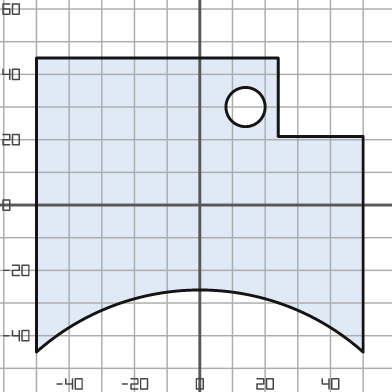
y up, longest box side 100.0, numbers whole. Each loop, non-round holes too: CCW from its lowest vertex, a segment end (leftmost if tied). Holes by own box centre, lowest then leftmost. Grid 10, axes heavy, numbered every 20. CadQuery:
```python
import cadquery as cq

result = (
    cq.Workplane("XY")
    .moveTo(-50.0, -45.0)
    .threePointArc((0.0, -26.0), (50.0, -45.0))
    .lineTo(50.0, 21.0)
    .lineTo(24.0, 21.0)
    .lineTo(24.0, 45.0)
    .lineTo(-50.0, 45.0)
    .close()
    .moveTo(14.0, 30.0)
    .circle(6.0)
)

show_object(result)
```